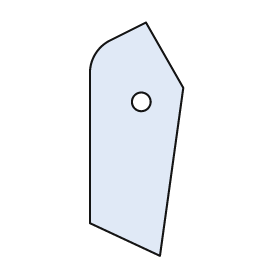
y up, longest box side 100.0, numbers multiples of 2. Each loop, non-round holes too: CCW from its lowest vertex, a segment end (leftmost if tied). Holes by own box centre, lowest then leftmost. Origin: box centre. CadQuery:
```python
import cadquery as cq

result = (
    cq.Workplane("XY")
    .moveTo(10.0, -50.0)
    .lineTo(20.0, 22.0)
    .lineTo(4.0, 50.0)
    .lineTo(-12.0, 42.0)
    .threePointArc((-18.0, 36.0), (-20.0, 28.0))
    .lineTo(-20.0, -36.0)
    .close()
    .moveTo(2.0, 16.0)
    .circle(4.0)
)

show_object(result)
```